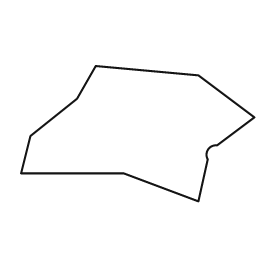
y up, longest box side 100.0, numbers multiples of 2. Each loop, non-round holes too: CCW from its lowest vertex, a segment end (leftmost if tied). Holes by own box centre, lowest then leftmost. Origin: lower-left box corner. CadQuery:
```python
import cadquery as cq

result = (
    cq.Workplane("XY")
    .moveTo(76.0, 0.0)
    .lineTo(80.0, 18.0)
    .threePointArc((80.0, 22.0), (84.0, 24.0))
    .lineTo(100.0, 36.0)
    .lineTo(76.0, 54.0)
    .lineTo(32.0, 58.0)
    .lineTo(24.0, 44.0)
    .lineTo(4.0, 28.0)
    .lineTo(0.0, 12.0)
    .lineTo(44.0, 12.0)
    .close()
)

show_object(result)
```